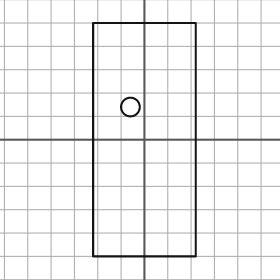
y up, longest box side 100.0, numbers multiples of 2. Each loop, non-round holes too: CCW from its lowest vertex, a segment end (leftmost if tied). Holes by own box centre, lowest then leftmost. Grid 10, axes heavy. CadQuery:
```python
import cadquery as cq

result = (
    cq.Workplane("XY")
    .moveTo(-22.0, -50.0)
    .lineTo(22.0, -50.0)
    .lineTo(22.0, 50.0)
    .lineTo(-22.0, 50.0)
    .close()
    .moveTo(-6.0, 14.0)
    .circle(4.0)
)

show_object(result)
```